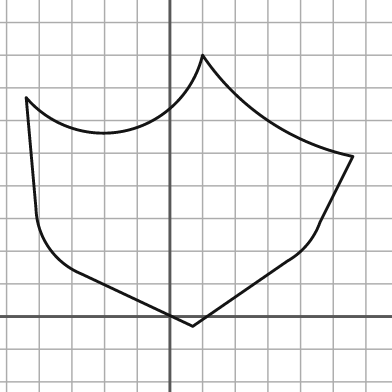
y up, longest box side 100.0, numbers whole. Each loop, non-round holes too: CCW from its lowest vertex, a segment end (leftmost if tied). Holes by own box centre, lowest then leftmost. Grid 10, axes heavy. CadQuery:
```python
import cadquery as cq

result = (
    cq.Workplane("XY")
    .moveTo(7.0, -3.0)
    .lineTo(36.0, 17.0)
    .threePointArc((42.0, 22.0), (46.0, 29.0))
    .lineTo(56.0, 49.0)
    .threePointArc((30.0, 60.0), (10.0, 80.0))
    .threePointArc((-13.0, 57.0), (-44.0, 67.0))
    .lineTo(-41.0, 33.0)
    .threePointArc((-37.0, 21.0), (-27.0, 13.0))
    .close()
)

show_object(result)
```